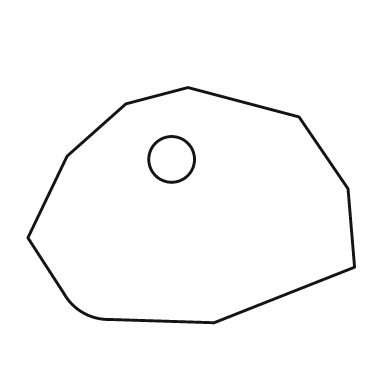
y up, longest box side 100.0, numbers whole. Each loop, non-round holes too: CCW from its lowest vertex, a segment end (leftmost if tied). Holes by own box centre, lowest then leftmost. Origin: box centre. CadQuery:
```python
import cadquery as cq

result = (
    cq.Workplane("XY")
    .moveTo(7.0, -36.0)
    .lineTo(50.0, -19.0)
    .lineTo(48.0, 5.0)
    .lineTo(33.0, 27.0)
    .lineTo(-1.0, 36.0)
    .lineTo(-20.0, 31.0)
    .lineTo(-38.0, 15.0)
    .lineTo(-50.0, -10.0)
    .lineTo(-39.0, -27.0)
    .threePointArc((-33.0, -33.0), (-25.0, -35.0))
    .close()
    .moveTo(-6.0, 14.0)
    .circle(7.0)
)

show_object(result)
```